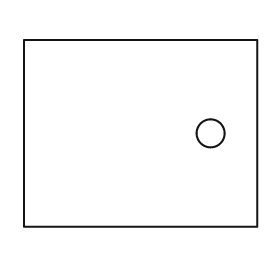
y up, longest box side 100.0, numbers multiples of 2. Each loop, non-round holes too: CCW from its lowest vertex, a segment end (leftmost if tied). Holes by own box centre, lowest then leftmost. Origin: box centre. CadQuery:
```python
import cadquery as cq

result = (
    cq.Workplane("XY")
    .moveTo(-50.0, -40.0)
    .lineTo(50.0, -40.0)
    .lineTo(50.0, 40.0)
    .lineTo(-50.0, 40.0)
    .close()
    .moveTo(30.0, 0.0)
    .circle(6.0)
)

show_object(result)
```